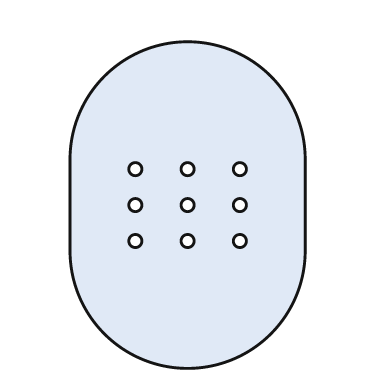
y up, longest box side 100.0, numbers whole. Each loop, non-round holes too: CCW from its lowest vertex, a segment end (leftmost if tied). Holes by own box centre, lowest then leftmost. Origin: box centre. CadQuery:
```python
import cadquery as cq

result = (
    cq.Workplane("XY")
    .moveTo(-36.0, -14.0)
    .threePointArc((0.0, -50.0), (36.0, -14.0))
    .lineTo(36.0, 14.0)
    .threePointArc((0.0, 50.0), (-36.0, 14.0))
    .close()
    .moveTo(-16.0, -11.0)
    .circle(2.0)
    .moveTo(0.0, -11.0)
    .circle(2.0)
    .moveTo(16.0, -11.0)
    .circle(2.0)
    .moveTo(-16.0, 0.0)
    .circle(2.0)
    .moveTo(0.0, 0.0)
    .circle(2.0)
    .moveTo(16.0, 0.0)
    .circle(2.0)
    .moveTo(-16.0, 11.0)
    .circle(2.0)
    .moveTo(0.0, 11.0)
    .circle(2.0)
    .moveTo(16.0, 11.0)
    .circle(2.0)
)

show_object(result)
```